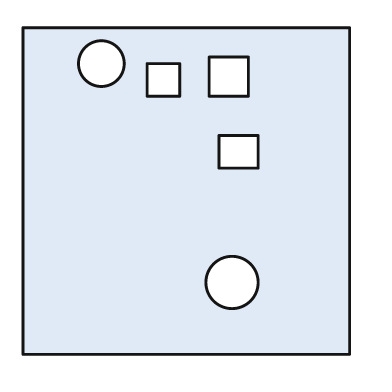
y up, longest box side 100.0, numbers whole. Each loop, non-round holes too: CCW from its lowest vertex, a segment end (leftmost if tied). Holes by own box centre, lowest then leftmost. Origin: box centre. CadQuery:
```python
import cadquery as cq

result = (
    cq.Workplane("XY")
    .moveTo(-50.0, -50.0)
    .lineTo(50.0, -50.0)
    .lineTo(50.0, 50.0)
    .lineTo(-50.0, 50.0)
    .close()
    .moveTo(14.0, -28.0)
    .circle(8.0)
    .moveTo(10.0, 7.0)
    .lineTo(22.0, 7.0)
    .lineTo(22.0, 17.0)
    .lineTo(10.0, 17.0)
    .close()
    .moveTo(-12.0, 29.0)
    .lineTo(-2.0, 29.0)
    .lineTo(-2.0, 39.0)
    .lineTo(-12.0, 39.0)
    .close()
    .moveTo(7.0, 29.0)
    .lineTo(19.0, 29.0)
    .lineTo(19.0, 41.0)
    .lineTo(7.0, 41.0)
    .close()
    .moveTo(-26.0, 39.0)
    .circle(7.0)
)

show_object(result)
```